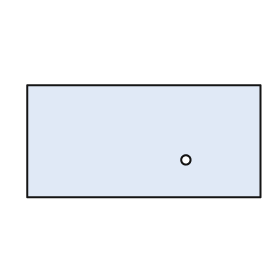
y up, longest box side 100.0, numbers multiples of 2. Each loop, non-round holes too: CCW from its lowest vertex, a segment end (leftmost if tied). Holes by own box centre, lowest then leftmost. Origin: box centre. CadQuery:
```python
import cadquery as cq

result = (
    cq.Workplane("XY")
    .moveTo(-50.0, -24.0)
    .lineTo(50.0, -24.0)
    .lineTo(50.0, 24.0)
    .lineTo(-50.0, 24.0)
    .close()
    .moveTo(18.0, -8.0)
    .circle(2.0)
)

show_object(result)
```